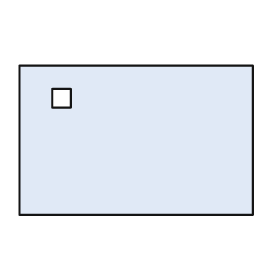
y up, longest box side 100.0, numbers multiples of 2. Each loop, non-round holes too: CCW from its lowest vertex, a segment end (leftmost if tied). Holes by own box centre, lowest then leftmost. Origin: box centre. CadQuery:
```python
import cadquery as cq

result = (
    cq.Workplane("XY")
    .moveTo(-50.0, -32.0)
    .lineTo(50.0, -32.0)
    .lineTo(50.0, 32.0)
    .lineTo(-50.0, 32.0)
    .close()
    .moveTo(-36.0, 14.0)
    .lineTo(-28.0, 14.0)
    .lineTo(-28.0, 22.0)
    .lineTo(-36.0, 22.0)
    .close()
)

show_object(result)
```